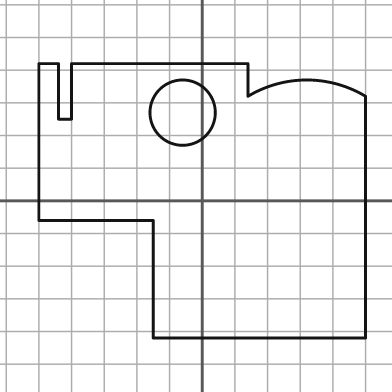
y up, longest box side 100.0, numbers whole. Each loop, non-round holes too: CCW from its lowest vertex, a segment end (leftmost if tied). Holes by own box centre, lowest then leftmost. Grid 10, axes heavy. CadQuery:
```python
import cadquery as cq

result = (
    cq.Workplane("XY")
    .moveTo(-15.0, -42.0)
    .lineTo(50.0, -42.0)
    .lineTo(50.0, 32.0)
    .threePointArc((32.0, 37.0), (14.0, 32.0))
    .lineTo(14.0, 42.0)
    .lineTo(-40.0, 42.0)
    .lineTo(-40.0, 25.0)
    .lineTo(-44.0, 25.0)
    .lineTo(-44.0, 42.0)
    .lineTo(-50.0, 42.0)
    .lineTo(-50.0, -6.0)
    .lineTo(-15.0, -6.0)
    .close()
    .moveTo(-6.0, 27.0)
    .circle(10.0)
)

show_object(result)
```